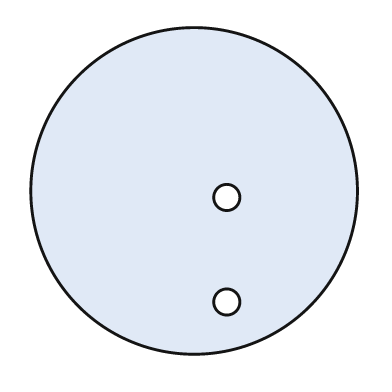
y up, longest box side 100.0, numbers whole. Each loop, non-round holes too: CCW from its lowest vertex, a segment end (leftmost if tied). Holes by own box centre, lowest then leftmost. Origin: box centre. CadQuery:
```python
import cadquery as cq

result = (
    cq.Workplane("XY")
    .moveTo(0.0, 0.0)
    .circle(50.0)
    .moveTo(10.0, -34.0)
    .circle(4.0)
    .moveTo(10.0, -2.0)
    .circle(4.0)
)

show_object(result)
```